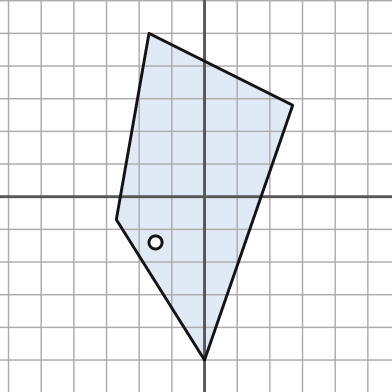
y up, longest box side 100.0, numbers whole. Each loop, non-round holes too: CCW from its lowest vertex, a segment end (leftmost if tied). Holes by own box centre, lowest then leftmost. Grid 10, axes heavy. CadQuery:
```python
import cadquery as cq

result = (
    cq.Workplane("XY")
    .moveTo(0.0, -50.0)
    .lineTo(27.0, 28.0)
    .lineTo(-17.0, 50.0)
    .lineTo(-27.0, -7.0)
    .close()
    .moveTo(-15.0, -14.0)
    .circle(2.0)
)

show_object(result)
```